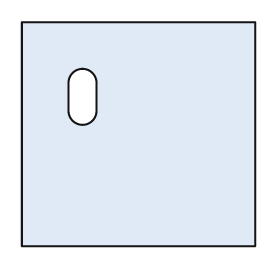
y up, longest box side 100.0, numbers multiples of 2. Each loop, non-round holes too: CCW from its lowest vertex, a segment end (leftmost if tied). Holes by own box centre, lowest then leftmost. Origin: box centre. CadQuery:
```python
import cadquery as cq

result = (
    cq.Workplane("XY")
    .moveTo(-50.0, -48.0)
    .lineTo(50.0, -48.0)
    .lineTo(50.0, 48.0)
    .lineTo(-50.0, 48.0)
    .close()
    .moveTo(-30.0, 10.0)
    .threePointArc((-24.0, 4.0), (-18.0, 10.0))
    .lineTo(-18.0, 22.0)
    .threePointArc((-24.0, 28.0), (-30.0, 22.0))
    .close()
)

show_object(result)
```